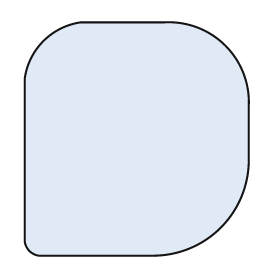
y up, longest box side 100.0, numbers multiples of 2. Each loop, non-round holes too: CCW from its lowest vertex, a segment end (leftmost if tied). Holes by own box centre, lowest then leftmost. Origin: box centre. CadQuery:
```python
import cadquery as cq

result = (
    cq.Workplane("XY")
    .moveTo(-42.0, -50.0)
    .lineTo(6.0, -50.0)
    .threePointArc((36.0, -38.0), (48.0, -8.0))
    .lineTo(48.0, 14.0)
    .threePointArc((38.0, 40.0), (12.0, 50.0))
    .lineTo(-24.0, 50.0)
    .threePointArc((-40.0, 42.0), (-48.0, 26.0))
    .lineTo(-48.0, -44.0)
    .threePointArc((-46.0, -48.0), (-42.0, -50.0))
    .close()
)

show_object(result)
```